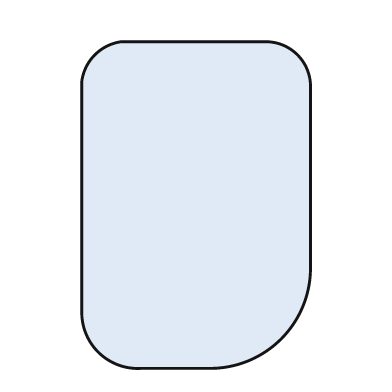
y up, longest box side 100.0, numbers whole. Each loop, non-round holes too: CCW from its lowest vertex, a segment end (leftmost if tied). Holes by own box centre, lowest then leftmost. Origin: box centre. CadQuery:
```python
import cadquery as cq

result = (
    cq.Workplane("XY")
    .moveTo(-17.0, -50.0)
    .lineTo(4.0, -50.0)
    .threePointArc((26.0, -41.0), (35.0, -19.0))
    .lineTo(35.0, 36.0)
    .threePointArc((31.0, 46.0), (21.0, 50.0))
    .lineTo(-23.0, 50.0)
    .threePointArc((-31.0, 46.0), (-35.0, 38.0))
    .lineTo(-35.0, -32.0)
    .threePointArc((-30.0, -45.0), (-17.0, -50.0))
    .close()
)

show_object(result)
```